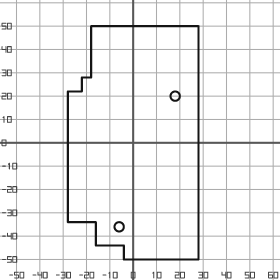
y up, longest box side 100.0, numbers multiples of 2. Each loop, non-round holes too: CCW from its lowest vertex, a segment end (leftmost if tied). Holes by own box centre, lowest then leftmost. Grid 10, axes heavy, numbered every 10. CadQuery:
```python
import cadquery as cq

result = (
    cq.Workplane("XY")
    .moveTo(-4.0, -50.0)
    .lineTo(28.0, -50.0)
    .lineTo(28.0, 50.0)
    .lineTo(-18.0, 50.0)
    .lineTo(-18.0, 28.0)
    .lineTo(-22.0, 28.0)
    .lineTo(-22.0, 22.0)
    .lineTo(-28.0, 22.0)
    .lineTo(-28.0, -34.0)
    .lineTo(-16.0, -34.0)
    .lineTo(-16.0, -44.0)
    .lineTo(-4.0, -44.0)
    .close()
    .moveTo(-6.0, -36.0)
    .circle(2.0)
    .moveTo(18.0, 20.0)
    .circle(2.0)
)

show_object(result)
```